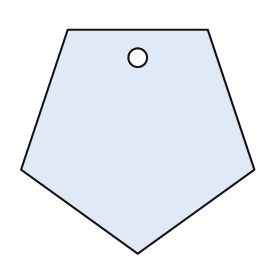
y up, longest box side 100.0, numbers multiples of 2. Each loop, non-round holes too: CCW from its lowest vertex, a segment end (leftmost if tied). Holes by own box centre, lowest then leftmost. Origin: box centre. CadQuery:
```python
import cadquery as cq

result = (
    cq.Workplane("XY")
    .moveTo(0.0, -48.0)
    .lineTo(50.0, -12.0)
    .lineTo(30.0, 48.0)
    .lineTo(-30.0, 48.0)
    .lineTo(-50.0, -12.0)
    .close()
    .moveTo(0.0, 36.0)
    .circle(4.0)
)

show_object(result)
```